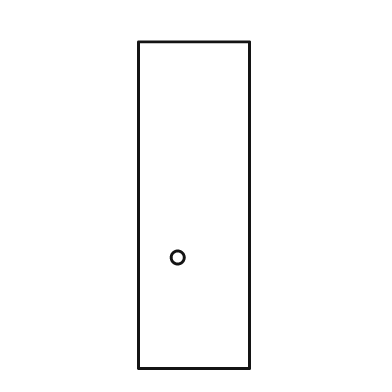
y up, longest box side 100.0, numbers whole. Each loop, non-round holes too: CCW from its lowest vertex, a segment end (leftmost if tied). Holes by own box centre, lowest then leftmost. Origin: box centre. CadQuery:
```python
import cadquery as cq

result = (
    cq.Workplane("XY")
    .moveTo(-17.0, -50.0)
    .lineTo(17.0, -50.0)
    .lineTo(17.0, 50.0)
    .lineTo(-17.0, 50.0)
    .close()
    .moveTo(-5.0, -16.0)
    .circle(2.0)
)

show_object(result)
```